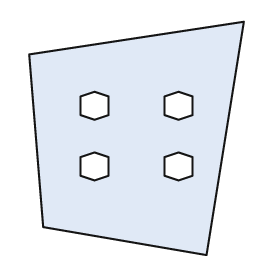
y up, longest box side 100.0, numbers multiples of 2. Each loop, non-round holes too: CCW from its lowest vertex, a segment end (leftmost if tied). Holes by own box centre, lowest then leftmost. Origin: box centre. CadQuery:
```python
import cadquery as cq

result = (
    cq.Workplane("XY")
    .moveTo(30.0, -50.0)
    .lineTo(46.0, 50.0)
    .lineTo(-46.0, 36.0)
    .lineTo(-40.0, -38.0)
    .close()
    .moveTo(-18.0, -18.0)
    .lineTo(-12.0, -16.0)
    .lineTo(-12.0, -8.0)
    .lineTo(-18.0, -6.0)
    .lineTo(-24.0, -8.0)
    .lineTo(-24.0, -16.0)
    .close()
    .moveTo(18.0, -18.0)
    .lineTo(24.0, -16.0)
    .lineTo(24.0, -8.0)
    .lineTo(18.0, -6.0)
    .lineTo(12.0, -8.0)
    .lineTo(12.0, -16.0)
    .close()
    .moveTo(-18.0, 8.0)
    .lineTo(-12.0, 10.0)
    .lineTo(-12.0, 18.0)
    .lineTo(-18.0, 20.0)
    .lineTo(-24.0, 18.0)
    .lineTo(-24.0, 10.0)
    .close()
    .moveTo(18.0, 8.0)
    .lineTo(24.0, 10.0)
    .lineTo(24.0, 18.0)
    .lineTo(18.0, 20.0)
    .lineTo(12.0, 18.0)
    .lineTo(12.0, 10.0)
    .close()
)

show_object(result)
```